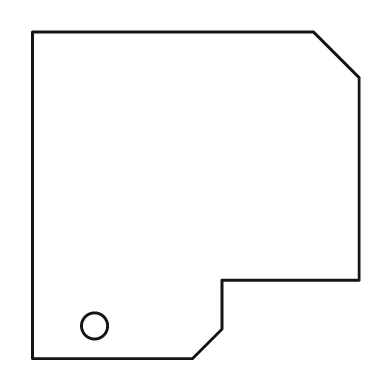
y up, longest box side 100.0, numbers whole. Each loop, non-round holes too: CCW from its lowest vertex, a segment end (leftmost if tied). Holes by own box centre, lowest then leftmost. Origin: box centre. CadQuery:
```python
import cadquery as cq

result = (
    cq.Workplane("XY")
    .moveTo(-50.0, -50.0)
    .lineTo(-1.0, -50.0)
    .lineTo(8.0, -41.0)
    .lineTo(8.0, -26.0)
    .lineTo(50.0, -26.0)
    .lineTo(50.0, 36.0)
    .lineTo(36.0, 50.0)
    .lineTo(-50.0, 50.0)
    .close()
    .moveTo(-31.0, -40.0)
    .circle(4.0)
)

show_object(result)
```